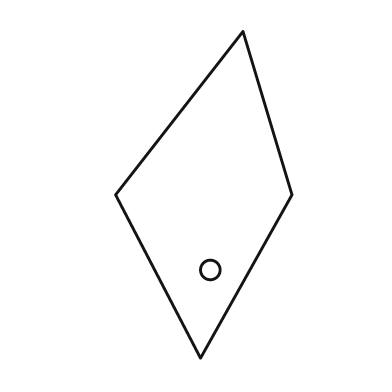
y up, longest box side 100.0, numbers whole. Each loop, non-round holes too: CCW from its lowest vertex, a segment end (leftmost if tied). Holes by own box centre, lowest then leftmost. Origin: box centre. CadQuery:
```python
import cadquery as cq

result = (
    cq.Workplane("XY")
    .moveTo(-1.0, -50.0)
    .lineTo(27.0, 0.0)
    .lineTo(12.0, 50.0)
    .lineTo(-27.0, 0.0)
    .close()
    .moveTo(2.0, -23.0)
    .circle(3.0)
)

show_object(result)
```